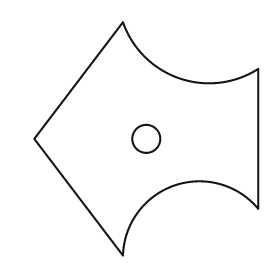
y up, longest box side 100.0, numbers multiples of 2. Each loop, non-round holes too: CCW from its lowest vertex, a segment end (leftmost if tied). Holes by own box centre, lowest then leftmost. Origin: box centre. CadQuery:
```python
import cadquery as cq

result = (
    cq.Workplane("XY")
    .moveTo(-10.0, -50.0)
    .threePointArc((12.0, -20.0), (48.0, -30.0))
    .lineTo(48.0, 30.0)
    .threePointArc((14.0, 26.0), (-10.0, 50.0))
    .lineTo(-48.0, 0.0)
    .close()
    .moveTo(0.0, 0.0)
    .circle(6.0)
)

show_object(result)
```